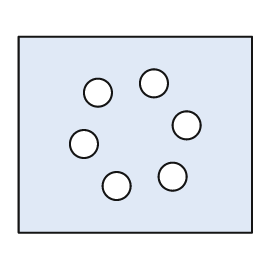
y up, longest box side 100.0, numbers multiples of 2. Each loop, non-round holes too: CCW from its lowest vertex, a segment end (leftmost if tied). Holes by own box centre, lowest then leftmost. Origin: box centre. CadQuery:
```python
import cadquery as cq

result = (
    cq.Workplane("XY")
    .moveTo(-50.0, -42.0)
    .lineTo(50.0, -42.0)
    .lineTo(50.0, 42.0)
    .lineTo(-50.0, 42.0)
    .close()
    .moveTo(-8.0, -22.0)
    .circle(6.0)
    .moveTo(16.0, -18.0)
    .circle(6.0)
    .moveTo(-22.0, -4.0)
    .circle(6.0)
    .moveTo(22.0, 4.0)
    .circle(6.0)
    .moveTo(-16.0, 18.0)
    .circle(6.0)
    .moveTo(8.0, 22.0)
    .circle(6.0)
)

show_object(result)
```